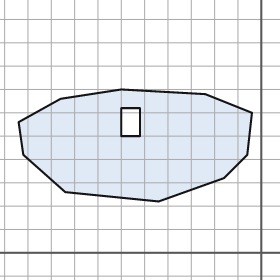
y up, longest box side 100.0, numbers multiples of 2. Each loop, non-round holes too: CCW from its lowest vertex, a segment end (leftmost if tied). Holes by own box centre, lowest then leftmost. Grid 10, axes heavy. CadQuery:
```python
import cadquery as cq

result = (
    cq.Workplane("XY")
    .moveTo(-44.0, 22.0)
    .lineTo(-16.0, 32.0)
    .lineTo(-6.0, 42.0)
    .lineTo(-4.0, 60.0)
    .lineTo(-24.0, 68.0)
    .lineTo(-60.0, 70.0)
    .lineTo(-86.0, 66.0)
    .lineTo(-104.0, 56.0)
    .lineTo(-102.0, 42.0)
    .lineTo(-84.0, 26.0)
    .close()
    .moveTo(-60.0, 50.0)
    .lineTo(-52.0, 50.0)
    .lineTo(-52.0, 62.0)
    .lineTo(-60.0, 62.0)
    .close()
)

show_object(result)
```